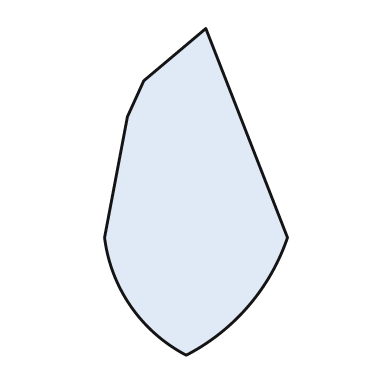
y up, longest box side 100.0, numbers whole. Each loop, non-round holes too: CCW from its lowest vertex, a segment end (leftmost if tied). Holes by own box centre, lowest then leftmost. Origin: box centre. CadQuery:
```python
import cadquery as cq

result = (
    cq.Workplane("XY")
    .moveTo(-3.0, -50.0)
    .threePointArc((16.0, -35.0), (28.0, -14.0))
    .lineTo(3.0, 50.0)
    .lineTo(-16.0, 34.0)
    .lineTo(-21.0, 23.0)
    .lineTo(-28.0, -14.0)
    .threePointArc((-20.0, -35.0), (-3.0, -50.0))
    .close()
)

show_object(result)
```